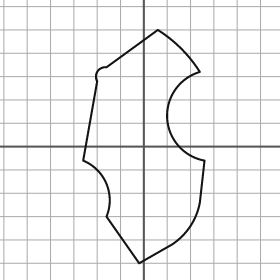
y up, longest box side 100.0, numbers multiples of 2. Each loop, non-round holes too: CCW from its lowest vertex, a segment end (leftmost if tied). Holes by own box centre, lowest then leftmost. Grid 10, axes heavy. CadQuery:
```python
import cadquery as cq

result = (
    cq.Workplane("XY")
    .moveTo(-2.0, -50.0)
    .lineTo(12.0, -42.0)
    .threePointArc((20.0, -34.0), (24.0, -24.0))
    .lineTo(26.0, -6.0)
    .threePointArc((10.0, 12.0), (24.0, 32.0))
    .threePointArc((16.0, 42.0), (6.0, 50.0))
    .lineTo(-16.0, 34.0)
    .threePointArc((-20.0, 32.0), (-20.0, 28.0))
    .lineTo(-26.0, -6.0)
    .threePointArc((-16.0, -16.0), (-16.0, -30.0))
    .close()
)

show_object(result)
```